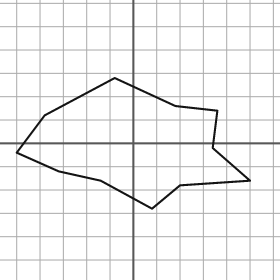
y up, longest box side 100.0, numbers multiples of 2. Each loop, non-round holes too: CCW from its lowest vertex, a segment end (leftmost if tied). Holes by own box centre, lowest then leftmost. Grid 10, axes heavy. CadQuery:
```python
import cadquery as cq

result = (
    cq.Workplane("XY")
    .moveTo(8.0, -28.0)
    .lineTo(20.0, -18.0)
    .lineTo(50.0, -16.0)
    .lineTo(34.0, -2.0)
    .lineTo(36.0, 14.0)
    .lineTo(18.0, 16.0)
    .lineTo(-8.0, 28.0)
    .lineTo(-38.0, 12.0)
    .lineTo(-50.0, -4.0)
    .lineTo(-32.0, -12.0)
    .lineTo(-14.0, -16.0)
    .close()
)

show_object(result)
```